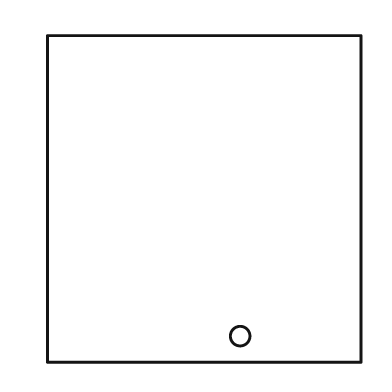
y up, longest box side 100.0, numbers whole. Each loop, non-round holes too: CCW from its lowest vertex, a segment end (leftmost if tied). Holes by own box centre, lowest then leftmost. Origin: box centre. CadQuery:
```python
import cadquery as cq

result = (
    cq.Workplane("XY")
    .moveTo(-48.0, -50.0)
    .lineTo(48.0, -50.0)
    .lineTo(48.0, 50.0)
    .lineTo(-48.0, 50.0)
    .close()
    .moveTo(11.0, -42.0)
    .circle(3.0)
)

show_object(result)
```